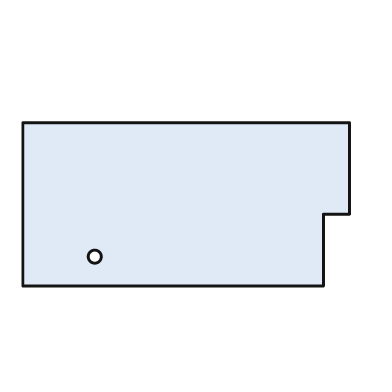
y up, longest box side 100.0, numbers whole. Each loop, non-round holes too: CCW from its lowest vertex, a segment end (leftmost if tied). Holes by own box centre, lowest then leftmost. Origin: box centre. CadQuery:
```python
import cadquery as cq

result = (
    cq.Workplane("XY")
    .moveTo(-50.0, -25.0)
    .lineTo(42.0, -25.0)
    .lineTo(42.0, -3.0)
    .lineTo(50.0, -3.0)
    .lineTo(50.0, 25.0)
    .lineTo(-50.0, 25.0)
    .close()
    .moveTo(-28.0, -16.0)
    .circle(2.0)
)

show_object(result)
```